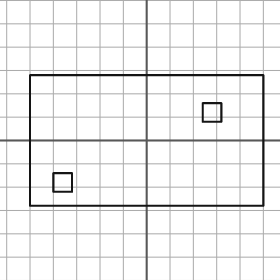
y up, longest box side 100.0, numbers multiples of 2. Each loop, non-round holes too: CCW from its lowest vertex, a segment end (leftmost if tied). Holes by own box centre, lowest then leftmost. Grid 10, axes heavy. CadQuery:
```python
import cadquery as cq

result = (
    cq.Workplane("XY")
    .moveTo(-50.0, -28.0)
    .lineTo(50.0, -28.0)
    .lineTo(50.0, 28.0)
    .lineTo(-50.0, 28.0)
    .close()
    .moveTo(-40.0, -22.0)
    .lineTo(-32.0, -22.0)
    .lineTo(-32.0, -14.0)
    .lineTo(-40.0, -14.0)
    .close()
    .moveTo(24.0, 8.0)
    .lineTo(32.0, 8.0)
    .lineTo(32.0, 16.0)
    .lineTo(24.0, 16.0)
    .close()
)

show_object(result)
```